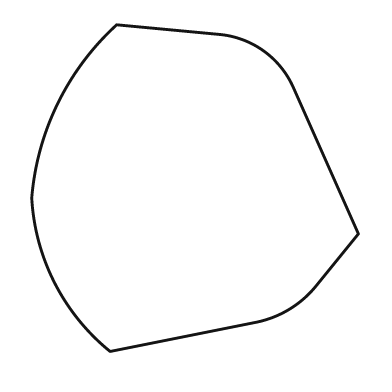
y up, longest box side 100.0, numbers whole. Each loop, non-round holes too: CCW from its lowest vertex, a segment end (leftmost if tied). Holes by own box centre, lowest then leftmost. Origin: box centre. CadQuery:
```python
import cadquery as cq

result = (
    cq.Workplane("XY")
    .moveTo(-26.0, -50.0)
    .lineTo(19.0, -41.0)
    .threePointArc((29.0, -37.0), (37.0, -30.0))
    .lineTo(50.0, -14.0)
    .lineTo(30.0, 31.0)
    .threePointArc((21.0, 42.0), (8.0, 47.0))
    .lineTo(-24.0, 50.0)
    .threePointArc((-42.0, 26.0), (-50.0, -3.0))
    .threePointArc((-43.0, -29.0), (-26.0, -50.0))
    .close()
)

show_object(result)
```